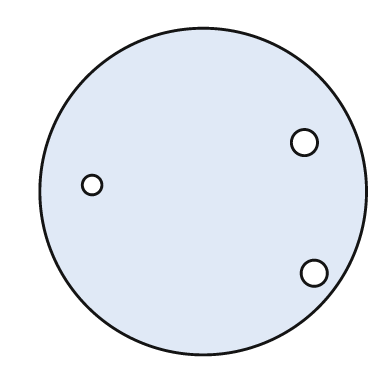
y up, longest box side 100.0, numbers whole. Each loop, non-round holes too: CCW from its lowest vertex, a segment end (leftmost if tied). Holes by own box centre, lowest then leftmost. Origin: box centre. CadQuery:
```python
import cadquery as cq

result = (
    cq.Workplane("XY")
    .moveTo(0.0, 0.0)
    .circle(50.0)
    .moveTo(34.0, -25.0)
    .circle(4.0)
    .moveTo(-34.0, 2.0)
    .circle(3.0)
    .moveTo(31.0, 15.0)
    .circle(4.0)
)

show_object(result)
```